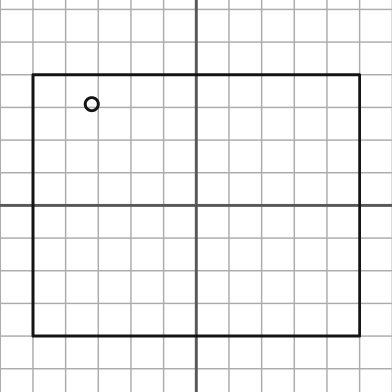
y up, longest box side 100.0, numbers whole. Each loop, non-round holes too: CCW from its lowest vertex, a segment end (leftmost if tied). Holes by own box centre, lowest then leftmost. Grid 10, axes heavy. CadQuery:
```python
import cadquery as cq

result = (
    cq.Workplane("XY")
    .moveTo(-50.0, -40.0)
    .lineTo(50.0, -40.0)
    .lineTo(50.0, 40.0)
    .lineTo(-50.0, 40.0)
    .close()
    .moveTo(-32.0, 31.0)
    .circle(2.0)
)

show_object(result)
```